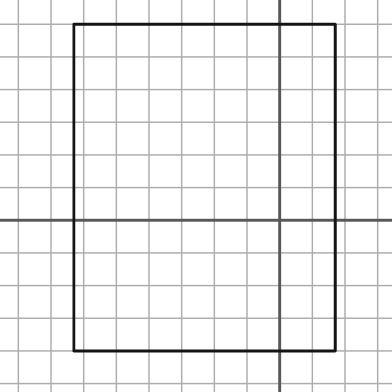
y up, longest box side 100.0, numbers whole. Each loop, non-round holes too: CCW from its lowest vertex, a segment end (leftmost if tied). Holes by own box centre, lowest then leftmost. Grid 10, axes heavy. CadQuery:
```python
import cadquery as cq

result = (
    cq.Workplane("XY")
    .moveTo(-63.0, -40.0)
    .lineTo(17.0, -40.0)
    .lineTo(17.0, 60.0)
    .lineTo(-63.0, 60.0)
    .close()
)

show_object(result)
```